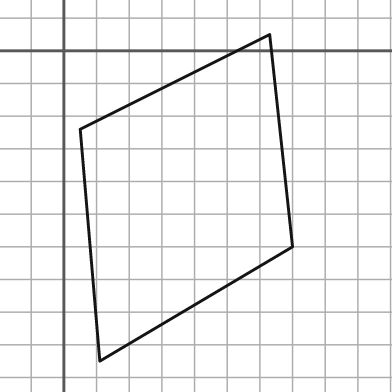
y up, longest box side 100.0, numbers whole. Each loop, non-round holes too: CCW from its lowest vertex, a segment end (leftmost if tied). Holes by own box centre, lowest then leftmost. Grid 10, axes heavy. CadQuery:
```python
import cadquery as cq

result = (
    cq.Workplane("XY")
    .moveTo(11.0, -95.0)
    .lineTo(70.0, -60.0)
    .lineTo(63.0, 5.0)
    .lineTo(5.0, -24.0)
    .close()
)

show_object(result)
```